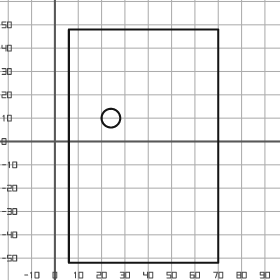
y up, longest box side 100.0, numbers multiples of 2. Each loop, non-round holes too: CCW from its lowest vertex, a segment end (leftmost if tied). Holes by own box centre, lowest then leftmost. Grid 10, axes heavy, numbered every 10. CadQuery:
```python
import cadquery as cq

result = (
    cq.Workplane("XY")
    .moveTo(6.0, -52.0)
    .lineTo(70.0, -52.0)
    .lineTo(70.0, 48.0)
    .lineTo(6.0, 48.0)
    .close()
    .moveTo(24.0, 10.0)
    .circle(4.0)
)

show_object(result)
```